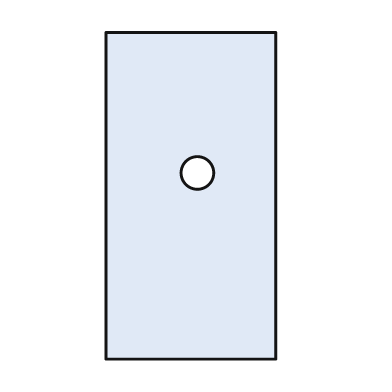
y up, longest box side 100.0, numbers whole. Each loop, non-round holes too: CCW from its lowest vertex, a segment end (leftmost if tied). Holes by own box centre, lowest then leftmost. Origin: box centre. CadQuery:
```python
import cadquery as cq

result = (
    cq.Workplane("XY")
    .moveTo(-26.0, -50.0)
    .lineTo(26.0, -50.0)
    .lineTo(26.0, 50.0)
    .lineTo(-26.0, 50.0)
    .close()
    .moveTo(2.0, 7.0)
    .circle(5.0)
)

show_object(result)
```